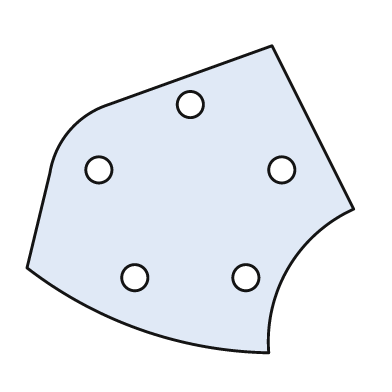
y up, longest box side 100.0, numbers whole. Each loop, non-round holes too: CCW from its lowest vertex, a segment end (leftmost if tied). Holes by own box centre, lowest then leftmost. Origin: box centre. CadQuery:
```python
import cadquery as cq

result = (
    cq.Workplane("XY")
    .moveTo(24.0, -47.0)
    .threePointArc((30.0, -21.0), (50.0, -3.0))
    .lineTo(25.0, 47.0)
    .lineTo(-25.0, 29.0)
    .threePointArc((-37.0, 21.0), (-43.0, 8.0))
    .lineTo(-50.0, -21.0)
    .threePointArc((-15.0, -40.0), (24.0, -47.0))
    .close()
    .moveTo(-17.0, -24.0)
    .circle(4.0)
    .moveTo(17.0, -24.0)
    .circle(4.0)
    .moveTo(-28.0, 9.0)
    .circle(4.0)
    .moveTo(28.0, 9.0)
    .circle(4.0)
    .moveTo(0.0, 29.0)
    .circle(4.0)
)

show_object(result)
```